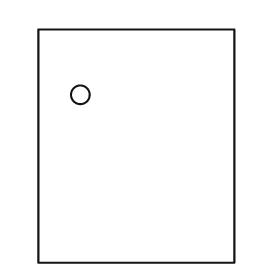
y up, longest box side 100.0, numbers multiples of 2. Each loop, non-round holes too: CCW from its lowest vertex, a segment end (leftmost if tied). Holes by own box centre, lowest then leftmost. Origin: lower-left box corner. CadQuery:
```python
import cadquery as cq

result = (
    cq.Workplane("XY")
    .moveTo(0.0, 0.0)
    .lineTo(84.0, 0.0)
    .lineTo(84.0, 100.0)
    .lineTo(0.0, 100.0)
    .close()
    .moveTo(18.0, 72.0)
    .circle(4.0)
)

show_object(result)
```